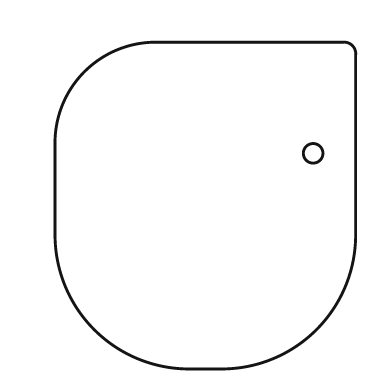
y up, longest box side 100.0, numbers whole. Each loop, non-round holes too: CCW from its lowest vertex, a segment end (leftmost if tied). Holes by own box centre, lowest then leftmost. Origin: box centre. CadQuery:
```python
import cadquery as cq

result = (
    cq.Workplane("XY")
    .moveTo(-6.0, -50.0)
    .lineTo(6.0, -50.0)
    .threePointArc((34.0, -38.0), (46.0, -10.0))
    .lineTo(46.0, 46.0)
    .threePointArc((45.0, 49.0), (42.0, 50.0))
    .lineTo(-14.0, 50.0)
    .threePointArc((-37.0, 41.0), (-46.0, 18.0))
    .lineTo(-46.0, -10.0)
    .threePointArc((-34.0, -38.0), (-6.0, -50.0))
    .close()
    .moveTo(33.0, 16.0)
    .circle(3.0)
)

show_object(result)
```